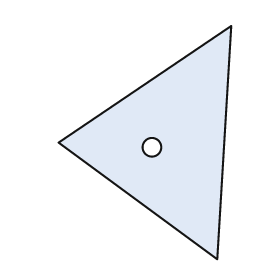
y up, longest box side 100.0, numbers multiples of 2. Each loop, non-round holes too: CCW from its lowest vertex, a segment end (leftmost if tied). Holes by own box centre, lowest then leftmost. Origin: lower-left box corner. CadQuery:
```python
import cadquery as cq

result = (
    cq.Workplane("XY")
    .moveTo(68.0, 0.0)
    .lineTo(74.0, 100.0)
    .lineTo(0.0, 50.0)
    .close()
    .moveTo(40.0, 48.0)
    .circle(4.0)
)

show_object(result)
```